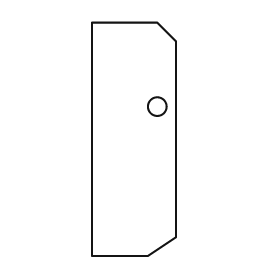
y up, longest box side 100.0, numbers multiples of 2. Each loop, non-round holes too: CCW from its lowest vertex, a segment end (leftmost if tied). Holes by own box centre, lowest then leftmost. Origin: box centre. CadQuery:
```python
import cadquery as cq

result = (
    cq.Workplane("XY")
    .moveTo(-18.0, -50.0)
    .lineTo(6.0, -50.0)
    .lineTo(18.0, -42.0)
    .lineTo(18.0, 42.0)
    .lineTo(10.0, 50.0)
    .lineTo(-18.0, 50.0)
    .close()
    .moveTo(10.0, 14.0)
    .circle(4.0)
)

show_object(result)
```